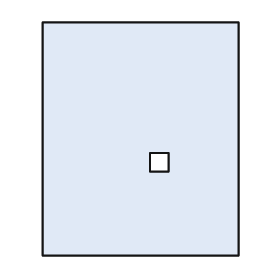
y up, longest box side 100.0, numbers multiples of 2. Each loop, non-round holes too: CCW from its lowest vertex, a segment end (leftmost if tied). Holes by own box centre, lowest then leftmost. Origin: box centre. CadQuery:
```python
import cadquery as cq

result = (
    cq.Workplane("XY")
    .moveTo(-42.0, -50.0)
    .lineTo(42.0, -50.0)
    .lineTo(42.0, 50.0)
    .lineTo(-42.0, 50.0)
    .close()
    .moveTo(4.0, -14.0)
    .lineTo(12.0, -14.0)
    .lineTo(12.0, -6.0)
    .lineTo(4.0, -6.0)
    .close()
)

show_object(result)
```